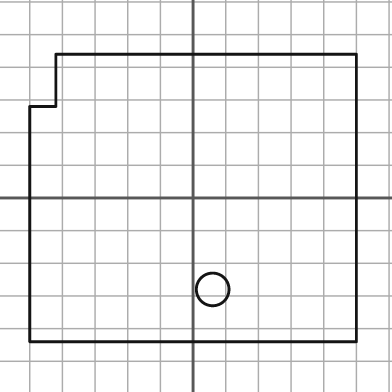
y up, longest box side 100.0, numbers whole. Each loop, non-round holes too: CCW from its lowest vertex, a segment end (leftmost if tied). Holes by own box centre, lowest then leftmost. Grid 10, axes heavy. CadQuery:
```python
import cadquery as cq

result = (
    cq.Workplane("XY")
    .moveTo(-50.0, -44.0)
    .lineTo(50.0, -44.0)
    .lineTo(50.0, 44.0)
    .lineTo(-42.0, 44.0)
    .lineTo(-42.0, 28.0)
    .lineTo(-50.0, 28.0)
    .close()
    .moveTo(6.0, -28.0)
    .circle(5.0)
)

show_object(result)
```